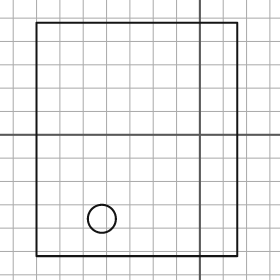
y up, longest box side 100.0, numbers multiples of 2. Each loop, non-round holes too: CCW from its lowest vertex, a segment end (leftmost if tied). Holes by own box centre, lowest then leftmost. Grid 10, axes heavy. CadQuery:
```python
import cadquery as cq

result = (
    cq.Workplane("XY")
    .moveTo(-70.0, -52.0)
    .lineTo(16.0, -52.0)
    .lineTo(16.0, 48.0)
    .lineTo(-70.0, 48.0)
    .close()
    .moveTo(-42.0, -36.0)
    .circle(6.0)
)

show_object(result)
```